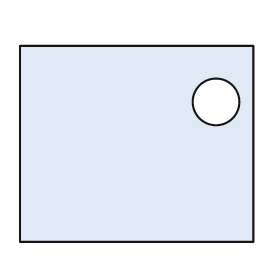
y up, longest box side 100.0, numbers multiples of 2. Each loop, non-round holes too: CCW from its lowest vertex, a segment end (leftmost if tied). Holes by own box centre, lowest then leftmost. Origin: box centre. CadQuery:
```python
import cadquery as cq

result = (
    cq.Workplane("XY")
    .moveTo(-50.0, -42.0)
    .lineTo(50.0, -42.0)
    .lineTo(50.0, 42.0)
    .lineTo(-50.0, 42.0)
    .close()
    .moveTo(34.0, 18.0)
    .circle(10.0)
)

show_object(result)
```